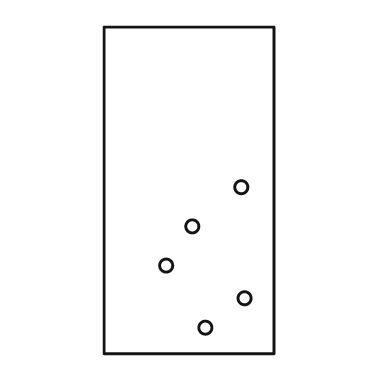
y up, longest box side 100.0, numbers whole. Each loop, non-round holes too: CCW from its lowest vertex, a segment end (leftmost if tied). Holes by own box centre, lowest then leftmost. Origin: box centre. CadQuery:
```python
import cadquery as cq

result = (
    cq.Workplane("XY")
    .moveTo(-26.0, -50.0)
    .lineTo(26.0, -50.0)
    .lineTo(26.0, 50.0)
    .lineTo(-26.0, 50.0)
    .close()
    .moveTo(5.0, -42.0)
    .circle(2.0)
    .moveTo(17.0, -33.0)
    .circle(2.0)
    .moveTo(-7.0, -23.0)
    .circle(2.0)
    .moveTo(1.0, -11.0)
    .circle(2.0)
    .moveTo(16.0, 1.0)
    .circle(2.0)
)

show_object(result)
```